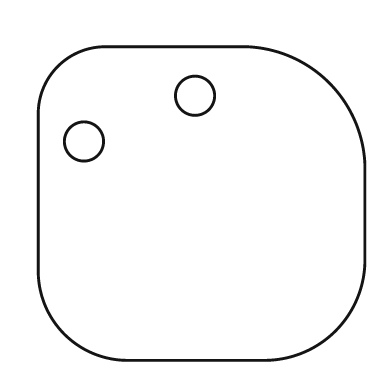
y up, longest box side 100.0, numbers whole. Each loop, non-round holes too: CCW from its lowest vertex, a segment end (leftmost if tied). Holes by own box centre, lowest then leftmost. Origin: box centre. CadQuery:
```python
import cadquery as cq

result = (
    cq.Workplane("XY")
    .moveTo(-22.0, -48.0)
    .lineTo(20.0, -48.0)
    .threePointArc((41.0, -39.0), (50.0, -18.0))
    .lineTo(50.0, 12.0)
    .threePointArc((39.0, 37.0), (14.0, 48.0))
    .lineTo(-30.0, 48.0)
    .threePointArc((-44.0, 42.0), (-50.0, 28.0))
    .lineTo(-50.0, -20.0)
    .threePointArc((-42.0, -40.0), (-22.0, -48.0))
    .close()
    .moveTo(-36.0, 19.0)
    .circle(6.0)
    .moveTo(-2.0, 33.0)
    .circle(6.0)
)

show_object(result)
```